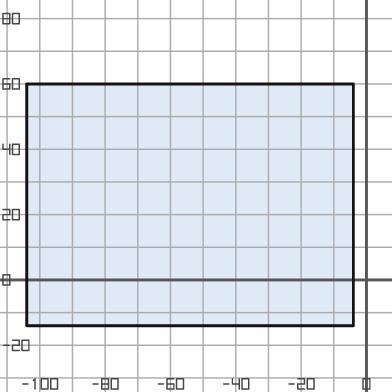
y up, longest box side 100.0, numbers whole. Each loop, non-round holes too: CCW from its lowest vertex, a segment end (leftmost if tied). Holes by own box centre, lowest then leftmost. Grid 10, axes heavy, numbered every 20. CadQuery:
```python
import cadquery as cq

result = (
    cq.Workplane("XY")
    .moveTo(-104.0, -14.0)
    .lineTo(-4.0, -14.0)
    .lineTo(-4.0, 60.0)
    .lineTo(-104.0, 60.0)
    .close()
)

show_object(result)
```